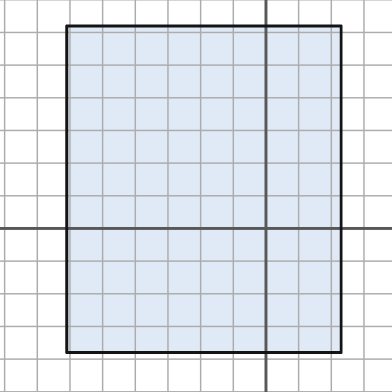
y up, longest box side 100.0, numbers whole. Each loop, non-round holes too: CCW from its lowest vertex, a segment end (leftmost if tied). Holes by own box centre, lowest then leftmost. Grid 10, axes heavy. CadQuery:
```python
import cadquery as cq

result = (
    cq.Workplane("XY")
    .moveTo(-61.0, -38.0)
    .lineTo(23.0, -38.0)
    .lineTo(23.0, 62.0)
    .lineTo(-61.0, 62.0)
    .close()
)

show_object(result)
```